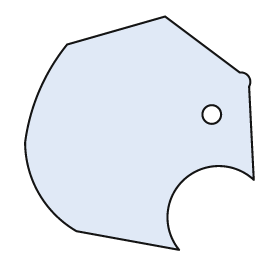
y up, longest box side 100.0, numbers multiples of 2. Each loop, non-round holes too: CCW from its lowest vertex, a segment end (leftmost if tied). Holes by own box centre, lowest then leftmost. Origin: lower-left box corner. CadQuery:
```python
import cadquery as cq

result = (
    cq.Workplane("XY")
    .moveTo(66.0, 0.0)
    .threePointArc((68.0, 30.0), (98.0, 30.0))
    .lineTo(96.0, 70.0)
    .threePointArc((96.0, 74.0), (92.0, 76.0))
    .lineTo(60.0, 100.0)
    .lineTo(18.0, 88.0)
    .threePointArc((6.0, 68.0), (0.0, 46.0))
    .threePointArc((6.0, 24.0), (22.0, 8.0))
    .close()
    .moveTo(80.0, 58.0)
    .circle(4.0)
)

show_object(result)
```